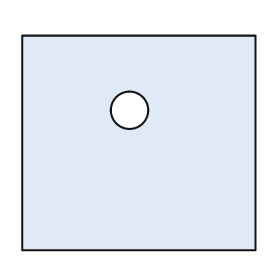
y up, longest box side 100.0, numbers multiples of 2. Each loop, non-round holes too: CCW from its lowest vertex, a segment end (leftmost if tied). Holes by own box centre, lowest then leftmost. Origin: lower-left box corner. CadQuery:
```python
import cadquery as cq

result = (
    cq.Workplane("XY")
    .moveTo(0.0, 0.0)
    .lineTo(100.0, 0.0)
    .lineTo(100.0, 92.0)
    .lineTo(0.0, 92.0)
    .close()
    .moveTo(46.0, 60.0)
    .circle(8.0)
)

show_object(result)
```